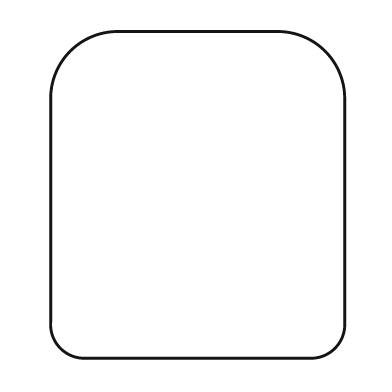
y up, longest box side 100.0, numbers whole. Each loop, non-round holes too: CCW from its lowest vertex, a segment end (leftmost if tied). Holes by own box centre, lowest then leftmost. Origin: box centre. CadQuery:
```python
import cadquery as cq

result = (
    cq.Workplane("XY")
    .moveTo(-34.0, -50.0)
    .lineTo(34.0, -50.0)
    .threePointArc((42.0, -47.0), (45.0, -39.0))
    .lineTo(45.0, 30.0)
    .threePointArc((39.0, 44.0), (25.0, 50.0))
    .lineTo(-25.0, 50.0)
    .threePointArc((-39.0, 44.0), (-45.0, 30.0))
    .lineTo(-45.0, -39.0)
    .threePointArc((-42.0, -47.0), (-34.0, -50.0))
    .close()
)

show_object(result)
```